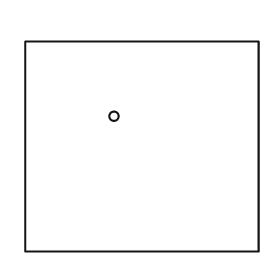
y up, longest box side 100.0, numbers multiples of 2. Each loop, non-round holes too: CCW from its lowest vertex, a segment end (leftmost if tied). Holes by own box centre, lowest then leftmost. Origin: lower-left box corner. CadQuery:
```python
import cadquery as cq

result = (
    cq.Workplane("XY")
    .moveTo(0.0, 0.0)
    .lineTo(100.0, 0.0)
    .lineTo(100.0, 90.0)
    .lineTo(0.0, 90.0)
    .close()
    .moveTo(38.0, 58.0)
    .circle(2.0)
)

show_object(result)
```